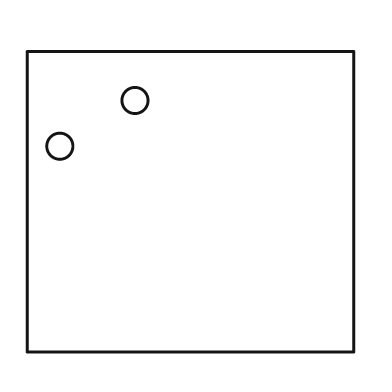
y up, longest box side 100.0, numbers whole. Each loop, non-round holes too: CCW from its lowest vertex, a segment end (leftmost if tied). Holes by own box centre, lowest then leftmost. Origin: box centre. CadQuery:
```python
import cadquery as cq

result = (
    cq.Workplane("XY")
    .moveTo(-50.0, -46.0)
    .lineTo(50.0, -46.0)
    .lineTo(50.0, 46.0)
    .lineTo(-50.0, 46.0)
    .close()
    .moveTo(-40.0, 17.0)
    .circle(4.0)
    .moveTo(-17.0, 31.0)
    .circle(4.0)
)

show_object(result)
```